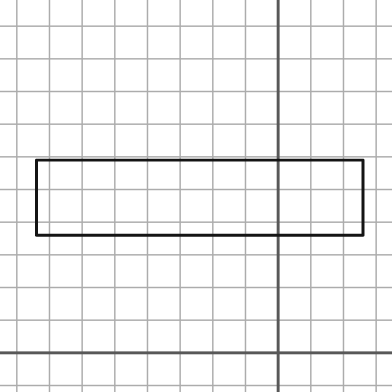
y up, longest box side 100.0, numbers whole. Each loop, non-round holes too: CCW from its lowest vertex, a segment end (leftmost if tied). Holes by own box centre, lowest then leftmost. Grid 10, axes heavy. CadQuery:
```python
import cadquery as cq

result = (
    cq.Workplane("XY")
    .moveTo(-74.0, 36.0)
    .lineTo(26.0, 36.0)
    .lineTo(26.0, 59.0)
    .lineTo(-74.0, 59.0)
    .close()
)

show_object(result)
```